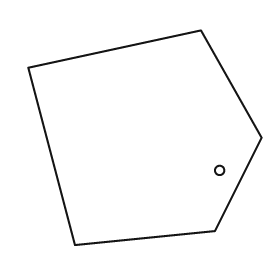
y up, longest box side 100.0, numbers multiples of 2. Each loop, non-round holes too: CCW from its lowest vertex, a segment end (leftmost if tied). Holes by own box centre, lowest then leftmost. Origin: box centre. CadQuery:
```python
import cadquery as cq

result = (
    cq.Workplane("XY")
    .moveTo(-30.0, -46.0)
    .lineTo(30.0, -40.0)
    .lineTo(50.0, 0.0)
    .lineTo(24.0, 46.0)
    .lineTo(-50.0, 30.0)
    .close()
    .moveTo(32.0, -14.0)
    .circle(2.0)
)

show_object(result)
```